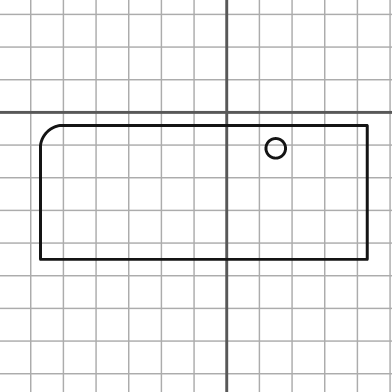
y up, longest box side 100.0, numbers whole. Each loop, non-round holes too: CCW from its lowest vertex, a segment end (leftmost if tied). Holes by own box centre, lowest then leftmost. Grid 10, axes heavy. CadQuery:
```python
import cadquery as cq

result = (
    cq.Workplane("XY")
    .moveTo(-57.0, -45.0)
    .lineTo(43.0, -45.0)
    .lineTo(43.0, -4.0)
    .lineTo(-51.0, -4.0)
    .threePointArc((-55.0, -6.0), (-57.0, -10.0))
    .close()
    .moveTo(15.0, -11.0)
    .circle(3.0)
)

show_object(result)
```